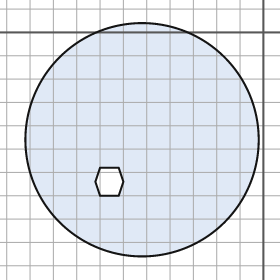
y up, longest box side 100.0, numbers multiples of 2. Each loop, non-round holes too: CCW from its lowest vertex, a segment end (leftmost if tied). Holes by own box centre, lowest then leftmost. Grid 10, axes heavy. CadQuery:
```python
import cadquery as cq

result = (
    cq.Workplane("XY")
    .moveTo(-52.0, -46.0)
    .circle(50.0)
    .moveTo(-70.0, -70.0)
    .lineTo(-62.0, -70.0)
    .lineTo(-60.0, -64.0)
    .lineTo(-62.0, -58.0)
    .lineTo(-70.0, -58.0)
    .lineTo(-72.0, -64.0)
    .close()
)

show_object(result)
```